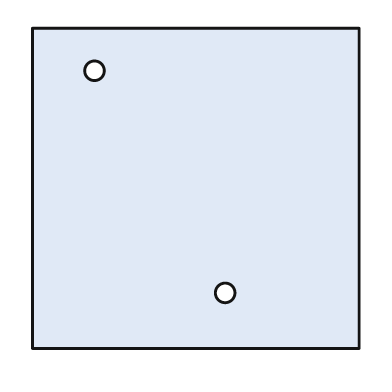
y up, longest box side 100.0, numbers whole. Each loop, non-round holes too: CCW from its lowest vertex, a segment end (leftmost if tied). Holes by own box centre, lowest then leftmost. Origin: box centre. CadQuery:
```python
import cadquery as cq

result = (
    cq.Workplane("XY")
    .moveTo(-50.0, -49.0)
    .lineTo(50.0, -49.0)
    .lineTo(50.0, 49.0)
    .lineTo(-50.0, 49.0)
    .close()
    .moveTo(9.0, -32.0)
    .circle(3.0)
    .moveTo(-31.0, 36.0)
    .circle(3.0)
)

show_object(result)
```